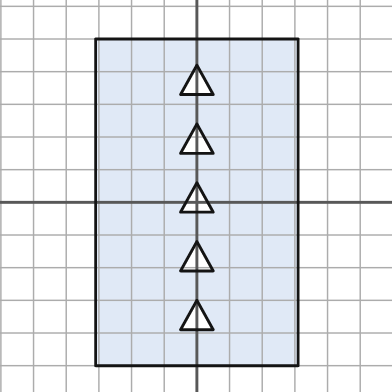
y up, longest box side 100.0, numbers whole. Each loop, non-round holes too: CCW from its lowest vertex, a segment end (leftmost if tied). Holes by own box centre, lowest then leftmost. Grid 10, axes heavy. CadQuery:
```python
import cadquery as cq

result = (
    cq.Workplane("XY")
    .moveTo(-31.0, -50.0)
    .lineTo(31.0, -50.0)
    .lineTo(31.0, 50.0)
    .lineTo(-31.0, 50.0)
    .close()
    .moveTo(-5.0, -39.0)
    .lineTo(5.0, -39.0)
    .lineTo(0.0, -30.0)
    .close()
    .moveTo(-5.0, -21.0)
    .lineTo(5.0, -21.0)
    .lineTo(0.0, -12.0)
    .close()
    .moveTo(-5.0, -3.0)
    .lineTo(5.0, -3.0)
    .lineTo(0.0, 6.0)
    .close()
    .moveTo(-5.0, 15.0)
    .lineTo(5.0, 15.0)
    .lineTo(0.0, 24.0)
    .close()
    .moveTo(-5.0, 33.0)
    .lineTo(5.0, 33.0)
    .lineTo(0.0, 42.0)
    .close()
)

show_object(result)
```